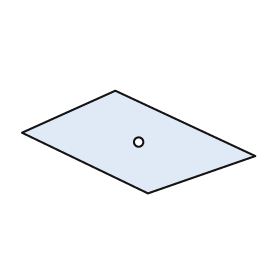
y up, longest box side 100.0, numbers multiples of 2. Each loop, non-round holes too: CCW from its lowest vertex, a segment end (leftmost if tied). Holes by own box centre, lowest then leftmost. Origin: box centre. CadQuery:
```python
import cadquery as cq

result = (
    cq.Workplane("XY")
    .moveTo(4.0, -22.0)
    .lineTo(50.0, -6.0)
    .lineTo(-10.0, 22.0)
    .lineTo(-50.0, 4.0)
    .close()
    .moveTo(0.0, 0.0)
    .circle(2.0)
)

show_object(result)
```